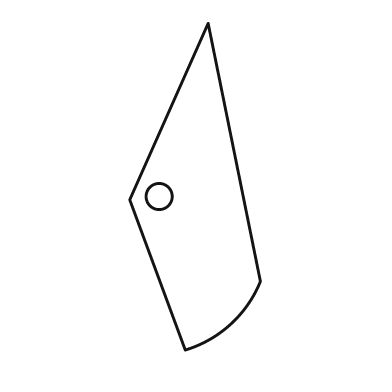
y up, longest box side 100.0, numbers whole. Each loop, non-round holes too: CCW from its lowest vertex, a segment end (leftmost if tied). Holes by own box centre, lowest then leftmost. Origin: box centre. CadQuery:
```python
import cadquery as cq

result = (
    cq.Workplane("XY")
    .moveTo(-3.0, -50.0)
    .threePointArc((11.0, -42.0), (20.0, -29.0))
    .lineTo(4.0, 50.0)
    .lineTo(-20.0, -4.0)
    .close()
    .moveTo(-11.0, -3.0)
    .circle(4.0)
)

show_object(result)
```